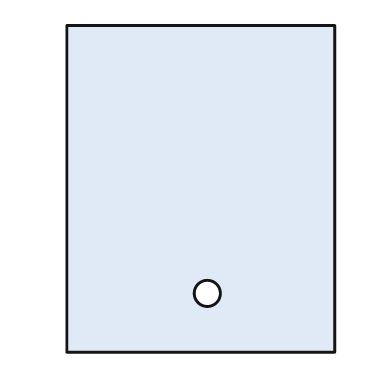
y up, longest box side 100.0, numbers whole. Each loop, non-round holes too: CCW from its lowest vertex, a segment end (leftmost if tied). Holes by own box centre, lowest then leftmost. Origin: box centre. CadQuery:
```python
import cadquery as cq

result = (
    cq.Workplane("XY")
    .moveTo(-41.0, -50.0)
    .lineTo(41.0, -50.0)
    .lineTo(41.0, 50.0)
    .lineTo(-41.0, 50.0)
    .close()
    .moveTo(2.0, -32.0)
    .circle(4.0)
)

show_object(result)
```